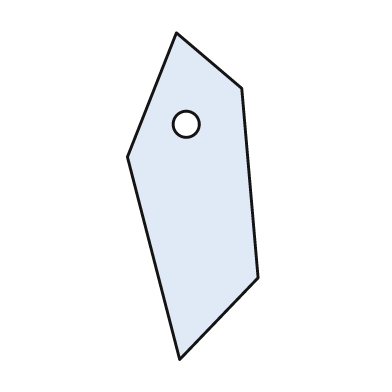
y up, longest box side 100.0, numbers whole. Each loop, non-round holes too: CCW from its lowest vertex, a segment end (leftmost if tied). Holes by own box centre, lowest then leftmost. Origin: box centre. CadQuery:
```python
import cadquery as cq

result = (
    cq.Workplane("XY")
    .moveTo(-4.0, -50.0)
    .lineTo(20.0, -25.0)
    .lineTo(15.0, 33.0)
    .lineTo(-5.0, 50.0)
    .lineTo(-20.0, 12.0)
    .close()
    .moveTo(-2.0, 22.0)
    .circle(4.0)
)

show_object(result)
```